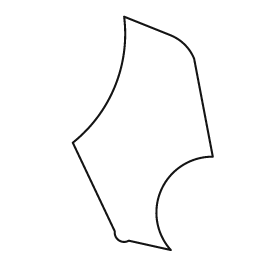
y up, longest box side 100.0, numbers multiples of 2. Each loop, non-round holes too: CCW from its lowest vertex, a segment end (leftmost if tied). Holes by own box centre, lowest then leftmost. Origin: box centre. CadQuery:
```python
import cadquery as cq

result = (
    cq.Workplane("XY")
    .moveTo(12.0, -50.0)
    .threePointArc((8.0, -24.0), (30.0, -10.0))
    .lineTo(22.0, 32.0)
    .threePointArc((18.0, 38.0), (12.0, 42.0))
    .lineTo(-8.0, 50.0)
    .threePointArc((-12.0, 20.0), (-30.0, -4.0))
    .lineTo(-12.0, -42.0)
    .threePointArc((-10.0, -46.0), (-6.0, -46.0))
    .close()
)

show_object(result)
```